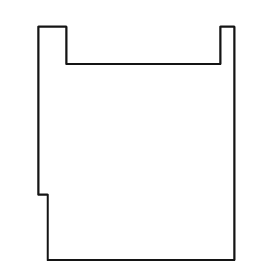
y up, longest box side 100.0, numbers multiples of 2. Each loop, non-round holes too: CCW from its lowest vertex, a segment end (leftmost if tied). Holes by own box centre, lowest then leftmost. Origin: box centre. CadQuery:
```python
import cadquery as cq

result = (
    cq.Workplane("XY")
    .moveTo(-38.0, -50.0)
    .lineTo(42.0, -50.0)
    .lineTo(42.0, 50.0)
    .lineTo(36.0, 50.0)
    .lineTo(36.0, 34.0)
    .lineTo(-30.0, 34.0)
    .lineTo(-30.0, 50.0)
    .lineTo(-42.0, 50.0)
    .lineTo(-42.0, -22.0)
    .lineTo(-38.0, -22.0)
    .close()
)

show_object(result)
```